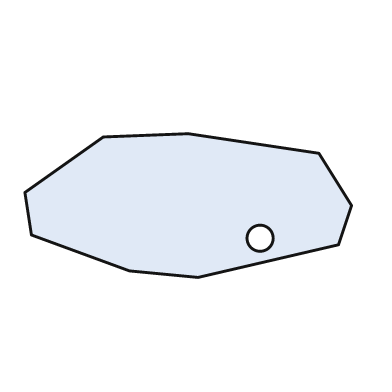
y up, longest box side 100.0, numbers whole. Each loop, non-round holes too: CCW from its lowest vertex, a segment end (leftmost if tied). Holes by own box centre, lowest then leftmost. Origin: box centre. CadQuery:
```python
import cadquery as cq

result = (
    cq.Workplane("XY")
    .moveTo(3.0, -22.0)
    .lineTo(46.0, -12.0)
    .lineTo(50.0, 0.0)
    .lineTo(40.0, 16.0)
    .lineTo(0.0, 22.0)
    .lineTo(-26.0, 21.0)
    .lineTo(-50.0, 4.0)
    .lineTo(-48.0, -9.0)
    .lineTo(-18.0, -20.0)
    .close()
    .moveTo(22.0, -10.0)
    .circle(4.0)
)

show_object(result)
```